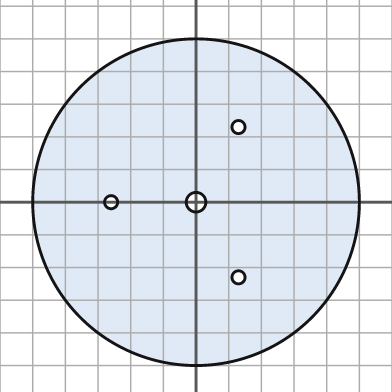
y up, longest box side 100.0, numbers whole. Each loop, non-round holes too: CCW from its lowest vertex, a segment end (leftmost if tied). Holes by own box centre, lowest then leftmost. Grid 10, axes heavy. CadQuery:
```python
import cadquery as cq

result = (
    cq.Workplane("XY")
    .moveTo(0.0, 0.0)
    .circle(50.0)
    .moveTo(13.0, -23.0)
    .circle(2.0)
    .moveTo(-26.0, 0.0)
    .circle(2.0)
    .moveTo(0.0, 0.0)
    .circle(3.0)
    .moveTo(13.0, 23.0)
    .circle(2.0)
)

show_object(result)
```